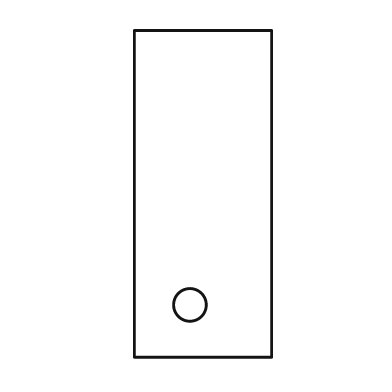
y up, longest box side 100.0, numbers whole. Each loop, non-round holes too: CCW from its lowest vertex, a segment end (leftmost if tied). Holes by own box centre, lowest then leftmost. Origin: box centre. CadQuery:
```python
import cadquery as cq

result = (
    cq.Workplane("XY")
    .moveTo(-21.0, -50.0)
    .lineTo(21.0, -50.0)
    .lineTo(21.0, 50.0)
    .lineTo(-21.0, 50.0)
    .close()
    .moveTo(-4.0, -34.0)
    .circle(5.0)
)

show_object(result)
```